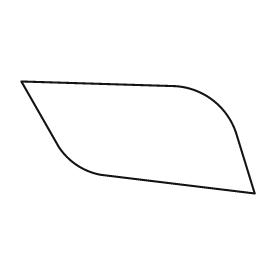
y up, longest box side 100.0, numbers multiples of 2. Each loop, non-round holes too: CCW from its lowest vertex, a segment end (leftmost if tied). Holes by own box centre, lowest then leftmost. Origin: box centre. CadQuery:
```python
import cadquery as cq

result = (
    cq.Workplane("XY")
    .moveTo(50.0, -24.0)
    .lineTo(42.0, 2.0)
    .threePointArc((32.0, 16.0), (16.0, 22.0))
    .lineTo(-50.0, 24.0)
    .lineTo(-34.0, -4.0)
    .threePointArc((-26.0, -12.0), (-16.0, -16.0))
    .close()
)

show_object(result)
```